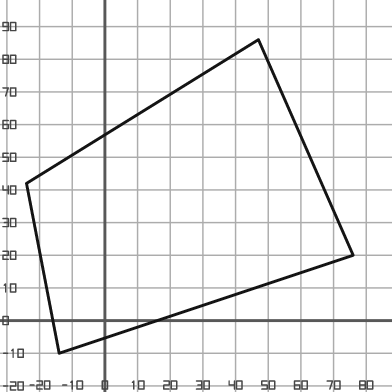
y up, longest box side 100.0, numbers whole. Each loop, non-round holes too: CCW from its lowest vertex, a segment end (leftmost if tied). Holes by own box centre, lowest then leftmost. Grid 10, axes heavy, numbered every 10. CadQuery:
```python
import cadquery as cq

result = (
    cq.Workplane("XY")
    .moveTo(-14.0, -10.0)
    .lineTo(76.0, 20.0)
    .lineTo(47.0, 86.0)
    .lineTo(-24.0, 42.0)
    .close()
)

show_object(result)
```